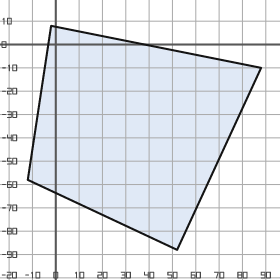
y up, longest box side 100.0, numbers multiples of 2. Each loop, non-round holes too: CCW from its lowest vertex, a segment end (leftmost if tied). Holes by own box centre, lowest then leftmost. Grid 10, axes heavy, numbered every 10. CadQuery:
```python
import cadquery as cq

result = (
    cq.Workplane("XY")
    .moveTo(52.0, -88.0)
    .lineTo(88.0, -10.0)
    .lineTo(-2.0, 8.0)
    .lineTo(-12.0, -58.0)
    .close()
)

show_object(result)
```